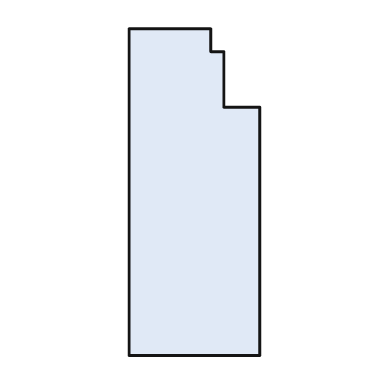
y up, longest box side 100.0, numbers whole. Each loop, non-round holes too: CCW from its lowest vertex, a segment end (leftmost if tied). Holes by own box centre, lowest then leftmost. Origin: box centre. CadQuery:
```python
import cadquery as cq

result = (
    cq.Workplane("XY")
    .moveTo(-20.0, -50.0)
    .lineTo(20.0, -50.0)
    .lineTo(20.0, 26.0)
    .lineTo(9.0, 26.0)
    .lineTo(9.0, 43.0)
    .lineTo(5.0, 43.0)
    .lineTo(5.0, 50.0)
    .lineTo(-20.0, 50.0)
    .close()
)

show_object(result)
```